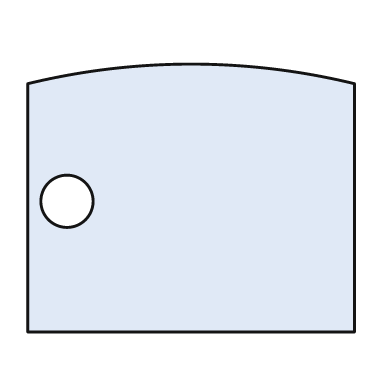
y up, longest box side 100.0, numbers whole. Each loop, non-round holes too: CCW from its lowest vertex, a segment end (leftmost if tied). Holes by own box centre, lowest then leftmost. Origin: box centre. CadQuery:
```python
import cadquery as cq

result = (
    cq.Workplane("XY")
    .moveTo(-50.0, -41.0)
    .lineTo(50.0, -41.0)
    .lineTo(50.0, 35.0)
    .threePointArc((0.0, 41.0), (-50.0, 35.0))
    .close()
    .moveTo(-38.0, -1.0)
    .circle(8.0)
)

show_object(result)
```